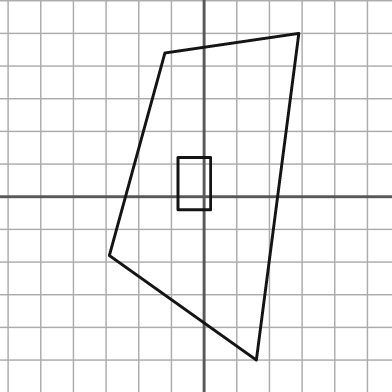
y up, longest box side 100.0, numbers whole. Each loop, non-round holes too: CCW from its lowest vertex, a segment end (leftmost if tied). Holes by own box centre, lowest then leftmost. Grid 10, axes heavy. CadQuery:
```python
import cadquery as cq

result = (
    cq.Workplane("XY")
    .moveTo(16.0, -50.0)
    .lineTo(29.0, 50.0)
    .lineTo(-12.0, 44.0)
    .lineTo(-29.0, -18.0)
    .close()
    .moveTo(-8.0, -4.0)
    .lineTo(2.0, -4.0)
    .lineTo(2.0, 12.0)
    .lineTo(-8.0, 12.0)
    .close()
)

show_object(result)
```